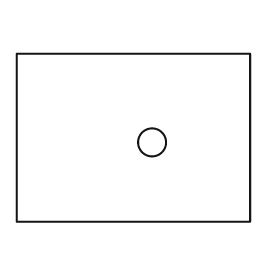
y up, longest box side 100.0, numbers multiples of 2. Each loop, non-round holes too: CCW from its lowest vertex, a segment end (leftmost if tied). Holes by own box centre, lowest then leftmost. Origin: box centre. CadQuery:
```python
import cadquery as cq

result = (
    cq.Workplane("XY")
    .moveTo(-50.0, -36.0)
    .lineTo(50.0, -36.0)
    .lineTo(50.0, 36.0)
    .lineTo(-50.0, 36.0)
    .close()
    .moveTo(8.0, -2.0)
    .circle(6.0)
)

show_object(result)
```